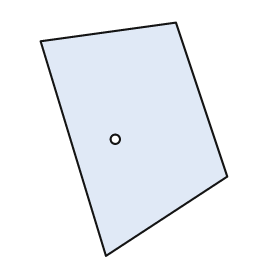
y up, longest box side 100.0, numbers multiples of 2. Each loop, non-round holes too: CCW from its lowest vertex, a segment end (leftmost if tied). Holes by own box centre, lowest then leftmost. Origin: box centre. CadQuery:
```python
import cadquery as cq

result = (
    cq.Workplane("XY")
    .moveTo(-12.0, -50.0)
    .lineTo(40.0, -16.0)
    .lineTo(18.0, 50.0)
    .lineTo(-40.0, 42.0)
    .close()
    .moveTo(-8.0, 0.0)
    .circle(2.0)
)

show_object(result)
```